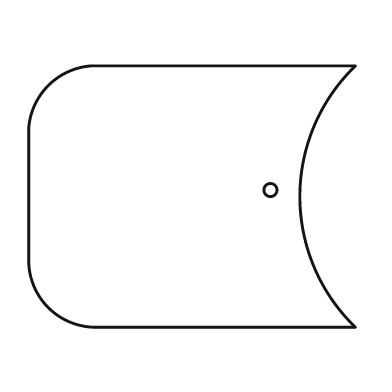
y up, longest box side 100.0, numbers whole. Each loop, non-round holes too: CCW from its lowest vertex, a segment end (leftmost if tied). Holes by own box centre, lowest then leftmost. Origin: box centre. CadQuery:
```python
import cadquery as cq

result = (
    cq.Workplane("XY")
    .moveTo(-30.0, -40.0)
    .lineTo(50.0, -40.0)
    .threePointArc((33.0, 0.0), (50.0, 40.0))
    .lineTo(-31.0, 40.0)
    .threePointArc((-44.0, 34.0), (-50.0, 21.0))
    .lineTo(-50.0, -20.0)
    .threePointArc((-44.0, -34.0), (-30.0, -40.0))
    .close()
    .moveTo(24.0, 2.0)
    .circle(2.0)
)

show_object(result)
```